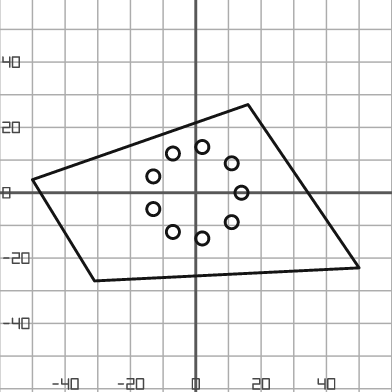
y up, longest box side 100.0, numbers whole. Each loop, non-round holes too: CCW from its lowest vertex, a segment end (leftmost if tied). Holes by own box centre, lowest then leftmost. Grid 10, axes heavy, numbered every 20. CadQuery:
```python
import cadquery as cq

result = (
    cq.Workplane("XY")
    .moveTo(-31.0, -27.0)
    .lineTo(50.0, -23.0)
    .lineTo(16.0, 27.0)
    .lineTo(-50.0, 4.0)
    .close()
    .moveTo(2.0, -14.0)
    .circle(2.0)
    .moveTo(-7.0, -12.0)
    .circle(2.0)
    .moveTo(11.0, -9.0)
    .circle(2.0)
    .moveTo(-13.0, -5.0)
    .circle(2.0)
    .moveTo(14.0, 0.0)
    .circle(2.0)
    .moveTo(-13.0, 5.0)
    .circle(2.0)
    .moveTo(11.0, 9.0)
    .circle(2.0)
    .moveTo(-7.0, 12.0)
    .circle(2.0)
    .moveTo(2.0, 14.0)
    .circle(2.0)
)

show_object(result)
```